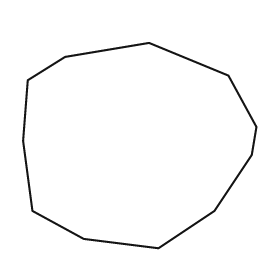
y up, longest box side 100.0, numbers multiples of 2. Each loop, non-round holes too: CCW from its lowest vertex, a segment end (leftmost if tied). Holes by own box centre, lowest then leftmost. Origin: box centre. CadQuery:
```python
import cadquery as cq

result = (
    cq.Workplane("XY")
    .moveTo(8.0, -44.0)
    .lineTo(32.0, -28.0)
    .lineTo(48.0, -4.0)
    .lineTo(50.0, 8.0)
    .lineTo(38.0, 30.0)
    .lineTo(4.0, 44.0)
    .lineTo(-32.0, 38.0)
    .lineTo(-48.0, 28.0)
    .lineTo(-50.0, 2.0)
    .lineTo(-46.0, -28.0)
    .lineTo(-24.0, -40.0)
    .close()
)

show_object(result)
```